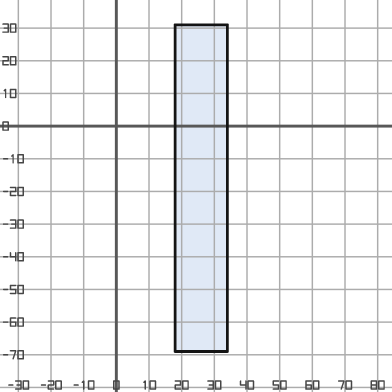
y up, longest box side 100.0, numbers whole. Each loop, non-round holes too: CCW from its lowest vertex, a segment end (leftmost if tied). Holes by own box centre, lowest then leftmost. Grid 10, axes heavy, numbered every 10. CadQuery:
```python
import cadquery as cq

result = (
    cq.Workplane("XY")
    .moveTo(18.0, -69.0)
    .lineTo(34.0, -69.0)
    .lineTo(34.0, 31.0)
    .lineTo(18.0, 31.0)
    .close()
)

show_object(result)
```